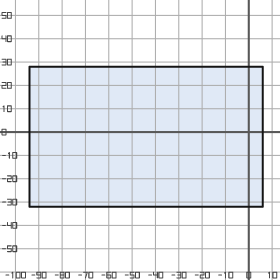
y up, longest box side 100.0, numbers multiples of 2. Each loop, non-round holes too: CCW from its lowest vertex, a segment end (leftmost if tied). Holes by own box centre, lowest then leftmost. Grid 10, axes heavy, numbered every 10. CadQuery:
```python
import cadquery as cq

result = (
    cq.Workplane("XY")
    .moveTo(-94.0, -32.0)
    .lineTo(6.0, -32.0)
    .lineTo(6.0, 28.0)
    .lineTo(-94.0, 28.0)
    .close()
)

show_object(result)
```